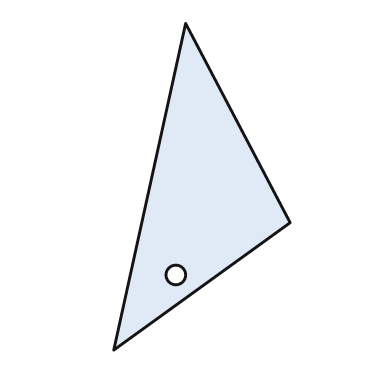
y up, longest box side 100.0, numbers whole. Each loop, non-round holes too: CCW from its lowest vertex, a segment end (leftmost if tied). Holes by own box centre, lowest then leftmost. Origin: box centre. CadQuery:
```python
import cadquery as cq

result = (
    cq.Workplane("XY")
    .moveTo(-27.0, -50.0)
    .lineTo(27.0, -11.0)
    .lineTo(-5.0, 50.0)
    .close()
    .moveTo(-8.0, -27.0)
    .circle(3.0)
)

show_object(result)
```